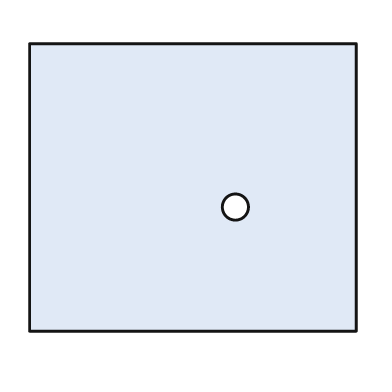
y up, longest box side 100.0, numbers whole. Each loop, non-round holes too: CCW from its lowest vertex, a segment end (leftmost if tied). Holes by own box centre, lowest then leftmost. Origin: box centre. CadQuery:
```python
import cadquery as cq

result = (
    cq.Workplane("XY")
    .moveTo(-50.0, -44.0)
    .lineTo(50.0, -44.0)
    .lineTo(50.0, 44.0)
    .lineTo(-50.0, 44.0)
    .close()
    .moveTo(13.0, -6.0)
    .circle(4.0)
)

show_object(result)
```